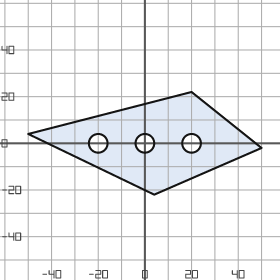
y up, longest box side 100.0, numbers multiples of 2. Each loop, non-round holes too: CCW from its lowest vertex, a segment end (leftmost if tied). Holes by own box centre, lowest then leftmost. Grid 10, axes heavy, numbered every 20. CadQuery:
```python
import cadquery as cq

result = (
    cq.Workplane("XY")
    .moveTo(4.0, -22.0)
    .lineTo(50.0, -2.0)
    .lineTo(20.0, 22.0)
    .lineTo(-50.0, 4.0)
    .close()
    .moveTo(-20.0, 0.0)
    .circle(4.0)
    .moveTo(0.0, 0.0)
    .circle(4.0)
    .moveTo(20.0, 0.0)
    .circle(4.0)
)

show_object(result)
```